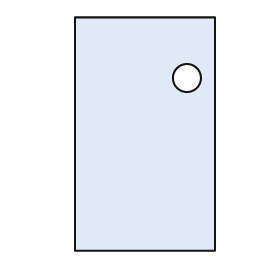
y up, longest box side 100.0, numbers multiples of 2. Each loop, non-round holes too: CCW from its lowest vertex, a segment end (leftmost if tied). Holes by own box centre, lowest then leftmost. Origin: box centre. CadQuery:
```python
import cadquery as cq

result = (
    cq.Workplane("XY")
    .moveTo(-30.0, -50.0)
    .lineTo(30.0, -50.0)
    .lineTo(30.0, 50.0)
    .lineTo(-30.0, 50.0)
    .close()
    .moveTo(18.0, 24.0)
    .circle(6.0)
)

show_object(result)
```